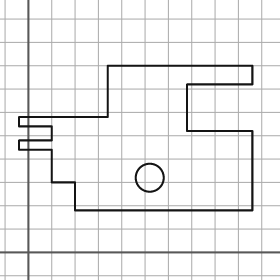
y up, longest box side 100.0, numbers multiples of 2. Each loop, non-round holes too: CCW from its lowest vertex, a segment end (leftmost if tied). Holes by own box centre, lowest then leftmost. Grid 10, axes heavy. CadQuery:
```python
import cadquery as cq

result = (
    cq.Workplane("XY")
    .moveTo(20.0, 18.0)
    .lineTo(96.0, 18.0)
    .lineTo(96.0, 52.0)
    .lineTo(68.0, 52.0)
    .lineTo(68.0, 72.0)
    .lineTo(96.0, 72.0)
    .lineTo(96.0, 80.0)
    .lineTo(34.0, 80.0)
    .lineTo(34.0, 58.0)
    .lineTo(-4.0, 58.0)
    .lineTo(-4.0, 54.0)
    .lineTo(10.0, 54.0)
    .lineTo(10.0, 48.0)
    .lineTo(-4.0, 48.0)
    .lineTo(-4.0, 44.0)
    .lineTo(10.0, 44.0)
    .lineTo(10.0, 30.0)
    .lineTo(20.0, 30.0)
    .close()
    .moveTo(52.0, 32.0)
    .circle(6.0)
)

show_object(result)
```